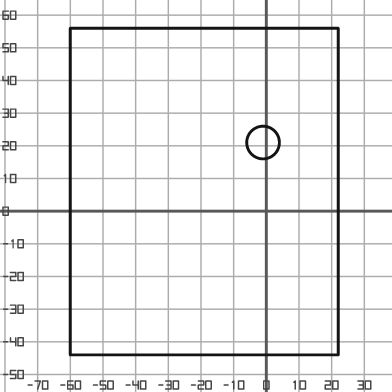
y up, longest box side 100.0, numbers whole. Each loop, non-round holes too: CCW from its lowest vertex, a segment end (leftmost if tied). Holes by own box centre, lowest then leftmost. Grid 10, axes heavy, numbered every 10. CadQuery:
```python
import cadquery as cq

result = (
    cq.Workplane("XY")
    .moveTo(-60.0, -44.0)
    .lineTo(22.0, -44.0)
    .lineTo(22.0, 56.0)
    .lineTo(-60.0, 56.0)
    .close()
    .moveTo(-1.0, 21.0)
    .circle(5.0)
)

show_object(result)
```